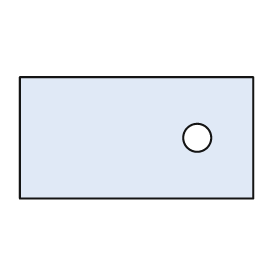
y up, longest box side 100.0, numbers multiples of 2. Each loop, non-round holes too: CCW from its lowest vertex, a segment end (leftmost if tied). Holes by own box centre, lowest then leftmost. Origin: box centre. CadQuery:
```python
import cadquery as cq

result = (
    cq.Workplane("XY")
    .moveTo(-50.0, -26.0)
    .lineTo(50.0, -26.0)
    .lineTo(50.0, 26.0)
    .lineTo(-50.0, 26.0)
    .close()
    .moveTo(26.0, 0.0)
    .circle(6.0)
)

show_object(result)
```